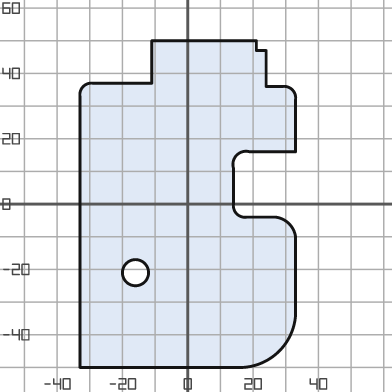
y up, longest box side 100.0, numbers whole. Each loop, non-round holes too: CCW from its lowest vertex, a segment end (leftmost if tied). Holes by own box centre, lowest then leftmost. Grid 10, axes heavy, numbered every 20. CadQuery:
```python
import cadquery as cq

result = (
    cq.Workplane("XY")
    .moveTo(-33.0, -50.0)
    .lineTo(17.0, -50.0)
    .threePointArc((28.0, -45.0), (33.0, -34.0))
    .lineTo(33.0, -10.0)
    .threePointArc((31.0, -6.0), (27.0, -4.0))
    .lineTo(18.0, -4.0)
    .threePointArc((15.0, -3.0), (14.0, 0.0))
    .lineTo(14.0, 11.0)
    .threePointArc((15.0, 15.0), (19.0, 16.0))
    .lineTo(33.0, 16.0)
    .lineTo(33.0, 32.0)
    .threePointArc((32.0, 35.0), (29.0, 36.0))
    .lineTo(24.0, 36.0)
    .lineTo(24.0, 47.0)
    .lineTo(21.0, 47.0)
    .lineTo(21.0, 50.0)
    .lineTo(-11.0, 50.0)
    .lineTo(-11.0, 37.0)
    .lineTo(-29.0, 37.0)
    .threePointArc((-32.0, 36.0), (-33.0, 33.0))
    .close()
    .moveTo(-16.0, -21.0)
    .circle(4.0)
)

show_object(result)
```